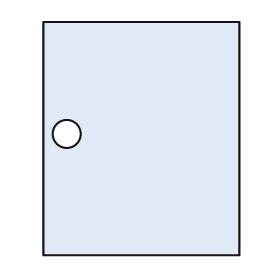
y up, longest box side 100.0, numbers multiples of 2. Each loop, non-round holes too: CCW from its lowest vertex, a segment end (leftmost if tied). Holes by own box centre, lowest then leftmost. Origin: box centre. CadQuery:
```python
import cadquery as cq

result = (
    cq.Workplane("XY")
    .moveTo(-42.0, -50.0)
    .lineTo(42.0, -50.0)
    .lineTo(42.0, 50.0)
    .lineTo(-42.0, 50.0)
    .close()
    .moveTo(-32.0, 2.0)
    .circle(6.0)
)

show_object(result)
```